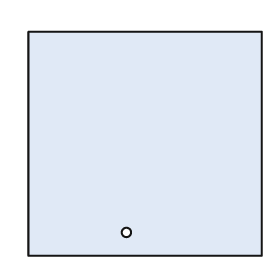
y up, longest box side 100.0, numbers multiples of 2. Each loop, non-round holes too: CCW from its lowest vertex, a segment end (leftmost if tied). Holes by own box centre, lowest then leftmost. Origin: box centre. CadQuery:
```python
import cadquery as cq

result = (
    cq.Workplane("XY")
    .moveTo(-50.0, -48.0)
    .lineTo(50.0, -48.0)
    .lineTo(50.0, 48.0)
    .lineTo(-50.0, 48.0)
    .close()
    .moveTo(-8.0, -38.0)
    .circle(2.0)
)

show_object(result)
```